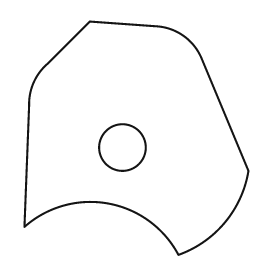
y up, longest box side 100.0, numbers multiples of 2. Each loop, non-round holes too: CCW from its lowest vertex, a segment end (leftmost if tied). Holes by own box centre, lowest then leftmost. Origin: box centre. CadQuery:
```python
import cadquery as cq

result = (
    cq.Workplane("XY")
    .moveTo(18.0, -50.0)
    .threePointArc((38.0, -36.0), (48.0, -14.0))
    .lineTo(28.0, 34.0)
    .threePointArc((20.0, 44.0), (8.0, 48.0))
    .lineTo(-20.0, 50.0)
    .lineTo(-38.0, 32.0)
    .threePointArc((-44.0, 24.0), (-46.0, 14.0))
    .lineTo(-48.0, -38.0)
    .threePointArc((-12.0, -28.0), (18.0, -50.0))
    .close()
    .moveTo(-6.0, -4.0)
    .circle(10.0)
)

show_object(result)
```